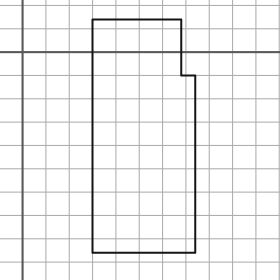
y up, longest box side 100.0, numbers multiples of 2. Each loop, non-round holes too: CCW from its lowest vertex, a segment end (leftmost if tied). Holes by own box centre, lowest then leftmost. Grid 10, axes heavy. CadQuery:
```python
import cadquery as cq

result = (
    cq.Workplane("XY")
    .moveTo(30.0, -86.0)
    .lineTo(74.0, -86.0)
    .lineTo(74.0, -10.0)
    .lineTo(68.0, -10.0)
    .lineTo(68.0, 14.0)
    .lineTo(30.0, 14.0)
    .close()
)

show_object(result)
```